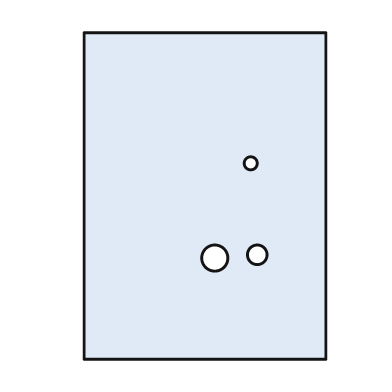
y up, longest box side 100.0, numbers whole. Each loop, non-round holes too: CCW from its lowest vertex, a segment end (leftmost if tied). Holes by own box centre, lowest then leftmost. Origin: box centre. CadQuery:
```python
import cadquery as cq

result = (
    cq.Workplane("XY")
    .moveTo(-37.0, -50.0)
    .lineTo(37.0, -50.0)
    .lineTo(37.0, 50.0)
    .lineTo(-37.0, 50.0)
    .close()
    .moveTo(3.0, -19.0)
    .circle(4.0)
    .moveTo(16.0, -18.0)
    .circle(3.0)
    .moveTo(14.0, 10.0)
    .circle(2.0)
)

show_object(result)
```